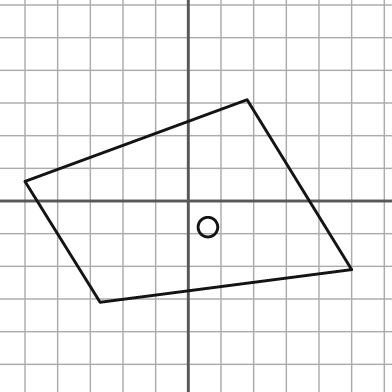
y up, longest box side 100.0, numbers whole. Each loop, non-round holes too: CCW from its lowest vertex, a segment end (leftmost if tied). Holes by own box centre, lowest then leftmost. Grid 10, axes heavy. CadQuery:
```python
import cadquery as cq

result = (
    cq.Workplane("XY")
    .moveTo(-27.0, -31.0)
    .lineTo(50.0, -21.0)
    .lineTo(18.0, 31.0)
    .lineTo(-50.0, 6.0)
    .close()
    .moveTo(6.0, -8.0)
    .circle(3.0)
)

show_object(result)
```